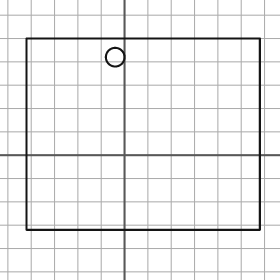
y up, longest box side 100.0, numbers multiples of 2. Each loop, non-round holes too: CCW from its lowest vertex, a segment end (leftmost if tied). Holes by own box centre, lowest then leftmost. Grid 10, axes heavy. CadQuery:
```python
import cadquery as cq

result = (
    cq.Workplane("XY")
    .moveTo(-42.0, -32.0)
    .lineTo(58.0, -32.0)
    .lineTo(58.0, 50.0)
    .lineTo(-42.0, 50.0)
    .close()
    .moveTo(-4.0, 42.0)
    .circle(4.0)
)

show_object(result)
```